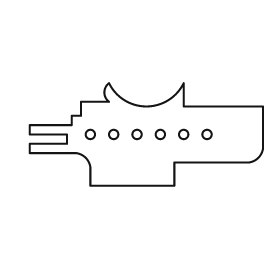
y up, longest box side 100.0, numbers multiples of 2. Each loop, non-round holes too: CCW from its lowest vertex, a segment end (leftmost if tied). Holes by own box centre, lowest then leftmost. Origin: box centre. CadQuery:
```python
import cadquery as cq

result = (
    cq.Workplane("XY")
    .moveTo(-24.0, -22.0)
    .lineTo(12.0, -22.0)
    .lineTo(12.0, -12.0)
    .lineTo(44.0, -12.0)
    .threePointArc((48.0, -10.0), (50.0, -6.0))
    .lineTo(50.0, 12.0)
    .lineTo(16.0, 12.0)
    .lineTo(16.0, 22.0)
    .threePointArc((0.0, 12.0), (-16.0, 22.0))
    .threePointArc((-18.0, 18.0), (-16.0, 14.0))
    .lineTo(-28.0, 14.0)
    .lineTo(-28.0, 8.0)
    .lineTo(-32.0, 8.0)
    .lineTo(-32.0, 4.0)
    .lineTo(-50.0, 4.0)
    .lineTo(-50.0, 0.0)
    .lineTo(-34.0, 0.0)
    .lineTo(-34.0, -4.0)
    .lineTo(-50.0, -4.0)
    .lineTo(-50.0, -8.0)
    .lineTo(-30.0, -8.0)
    .threePointArc((-26.0, -10.0), (-24.0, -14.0))
    .close()
    .moveTo(-24.0, 0.0)
    .circle(2.0)
    .moveTo(-14.0, 0.0)
    .circle(2.0)
    .moveTo(-4.0, 0.0)
    .circle(2.0)
    .moveTo(6.0, 0.0)
    .circle(2.0)
    .moveTo(16.0, 0.0)
    .circle(2.0)
    .moveTo(26.0, 0.0)
    .circle(2.0)
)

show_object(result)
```